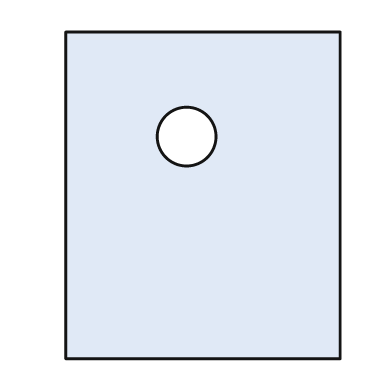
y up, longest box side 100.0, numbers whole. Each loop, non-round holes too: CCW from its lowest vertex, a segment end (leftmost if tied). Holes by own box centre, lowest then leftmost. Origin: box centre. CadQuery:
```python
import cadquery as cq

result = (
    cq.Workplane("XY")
    .moveTo(-42.0, -50.0)
    .lineTo(42.0, -50.0)
    .lineTo(42.0, 50.0)
    .lineTo(-42.0, 50.0)
    .close()
    .moveTo(-5.0, 18.0)
    .circle(9.0)
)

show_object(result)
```